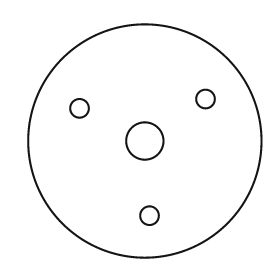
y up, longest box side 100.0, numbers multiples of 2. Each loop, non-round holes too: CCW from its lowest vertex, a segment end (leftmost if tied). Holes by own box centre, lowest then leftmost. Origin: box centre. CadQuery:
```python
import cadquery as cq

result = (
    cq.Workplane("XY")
    .moveTo(0.0, 0.0)
    .circle(50.0)
    .moveTo(2.0, -32.0)
    .circle(4.0)
    .moveTo(0.0, 0.0)
    .circle(8.0)
    .moveTo(-28.0, 14.0)
    .circle(4.0)
    .moveTo(26.0, 18.0)
    .circle(4.0)
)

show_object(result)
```